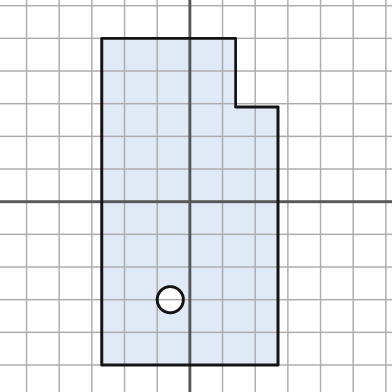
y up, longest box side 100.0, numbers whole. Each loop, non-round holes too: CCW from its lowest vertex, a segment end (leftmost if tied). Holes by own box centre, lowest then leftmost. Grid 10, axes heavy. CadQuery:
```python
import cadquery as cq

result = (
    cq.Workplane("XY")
    .moveTo(-27.0, -50.0)
    .lineTo(27.0, -50.0)
    .lineTo(27.0, 29.0)
    .lineTo(14.0, 29.0)
    .lineTo(14.0, 50.0)
    .lineTo(-27.0, 50.0)
    .close()
    .moveTo(-6.0, -30.0)
    .circle(4.0)
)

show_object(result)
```